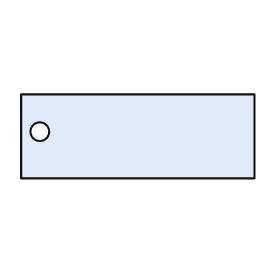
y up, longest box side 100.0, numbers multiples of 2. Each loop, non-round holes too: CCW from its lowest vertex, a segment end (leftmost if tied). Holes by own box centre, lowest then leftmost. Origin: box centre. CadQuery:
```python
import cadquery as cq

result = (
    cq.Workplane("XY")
    .moveTo(-50.0, -18.0)
    .lineTo(50.0, -18.0)
    .lineTo(50.0, 18.0)
    .lineTo(-50.0, 18.0)
    .close()
    .moveTo(-42.0, 2.0)
    .circle(4.0)
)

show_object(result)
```